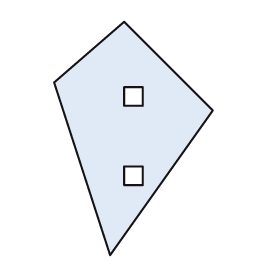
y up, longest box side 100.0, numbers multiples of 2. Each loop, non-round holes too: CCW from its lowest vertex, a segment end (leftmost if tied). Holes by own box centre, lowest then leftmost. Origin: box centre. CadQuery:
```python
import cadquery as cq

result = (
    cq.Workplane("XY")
    .moveTo(-10.0, -50.0)
    .lineTo(34.0, 12.0)
    .lineTo(-4.0, 50.0)
    .lineTo(-34.0, 24.0)
    .close()
    .moveTo(-4.0, -20.0)
    .lineTo(4.0, -20.0)
    .lineTo(4.0, -12.0)
    .lineTo(-4.0, -12.0)
    .close()
    .moveTo(-4.0, 14.0)
    .lineTo(4.0, 14.0)
    .lineTo(4.0, 22.0)
    .lineTo(-4.0, 22.0)
    .close()
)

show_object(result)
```